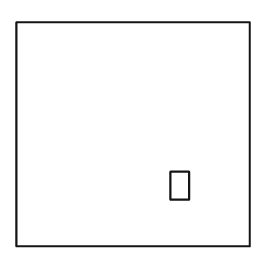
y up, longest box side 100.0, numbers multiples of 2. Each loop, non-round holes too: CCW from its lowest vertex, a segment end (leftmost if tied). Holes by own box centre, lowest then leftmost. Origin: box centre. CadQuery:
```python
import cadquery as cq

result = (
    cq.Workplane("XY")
    .moveTo(-50.0, -48.0)
    .lineTo(50.0, -48.0)
    .lineTo(50.0, 48.0)
    .lineTo(-50.0, 48.0)
    .close()
    .moveTo(16.0, -28.0)
    .lineTo(24.0, -28.0)
    .lineTo(24.0, -16.0)
    .lineTo(16.0, -16.0)
    .close()
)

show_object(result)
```